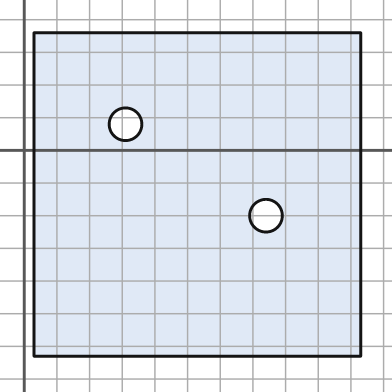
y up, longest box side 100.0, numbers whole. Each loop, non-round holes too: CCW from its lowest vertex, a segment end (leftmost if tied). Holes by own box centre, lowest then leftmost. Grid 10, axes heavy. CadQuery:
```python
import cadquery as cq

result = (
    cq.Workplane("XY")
    .moveTo(3.0, -63.0)
    .lineTo(103.0, -63.0)
    .lineTo(103.0, 36.0)
    .lineTo(3.0, 36.0)
    .close()
    .moveTo(74.0, -20.0)
    .circle(5.0)
    .moveTo(31.0, 8.0)
    .circle(5.0)
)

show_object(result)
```